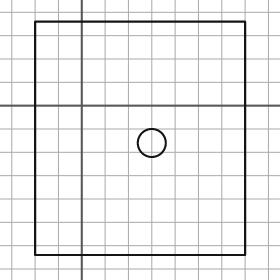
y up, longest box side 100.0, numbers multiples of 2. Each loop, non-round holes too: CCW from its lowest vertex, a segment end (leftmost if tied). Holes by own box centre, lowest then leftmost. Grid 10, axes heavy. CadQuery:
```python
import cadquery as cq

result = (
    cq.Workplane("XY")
    .moveTo(-20.0, -64.0)
    .lineTo(70.0, -64.0)
    .lineTo(70.0, 36.0)
    .lineTo(-20.0, 36.0)
    .close()
    .moveTo(30.0, -16.0)
    .circle(6.0)
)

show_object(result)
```